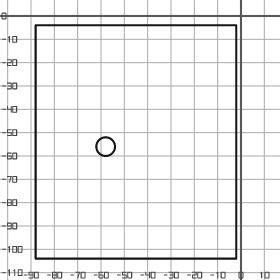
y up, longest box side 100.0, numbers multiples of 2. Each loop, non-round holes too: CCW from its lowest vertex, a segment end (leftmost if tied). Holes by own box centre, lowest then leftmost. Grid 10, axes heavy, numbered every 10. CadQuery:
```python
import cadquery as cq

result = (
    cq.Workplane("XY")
    .moveTo(-88.0, -104.0)
    .lineTo(-2.0, -104.0)
    .lineTo(-2.0, -4.0)
    .lineTo(-88.0, -4.0)
    .close()
    .moveTo(-58.0, -56.0)
    .circle(4.0)
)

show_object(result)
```